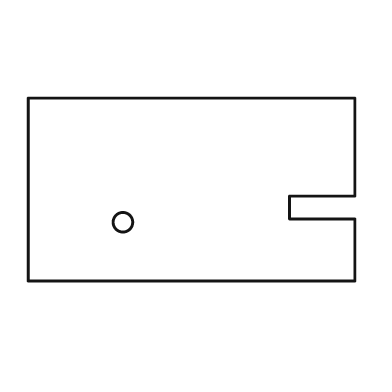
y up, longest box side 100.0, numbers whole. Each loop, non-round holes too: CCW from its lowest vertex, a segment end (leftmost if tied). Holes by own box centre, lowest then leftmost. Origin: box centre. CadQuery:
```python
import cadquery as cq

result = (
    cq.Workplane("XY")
    .moveTo(-50.0, -28.0)
    .lineTo(50.0, -28.0)
    .lineTo(50.0, -9.0)
    .lineTo(30.0, -9.0)
    .lineTo(30.0, -2.0)
    .lineTo(50.0, -2.0)
    .lineTo(50.0, 28.0)
    .lineTo(-50.0, 28.0)
    .close()
    .moveTo(-21.0, -10.0)
    .circle(3.0)
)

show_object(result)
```